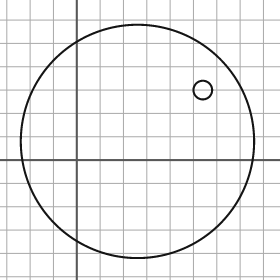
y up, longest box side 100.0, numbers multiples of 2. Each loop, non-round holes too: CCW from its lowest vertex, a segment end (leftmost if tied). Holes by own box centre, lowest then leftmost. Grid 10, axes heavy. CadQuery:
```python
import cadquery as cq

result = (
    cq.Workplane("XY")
    .moveTo(26.0, 8.0)
    .circle(50.0)
    .moveTo(54.0, 30.0)
    .circle(4.0)
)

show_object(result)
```